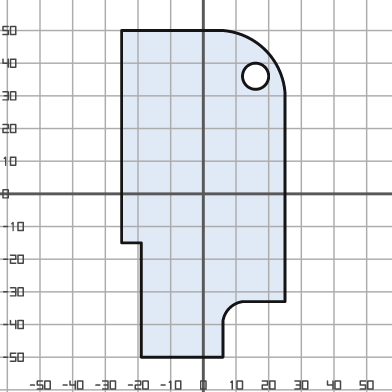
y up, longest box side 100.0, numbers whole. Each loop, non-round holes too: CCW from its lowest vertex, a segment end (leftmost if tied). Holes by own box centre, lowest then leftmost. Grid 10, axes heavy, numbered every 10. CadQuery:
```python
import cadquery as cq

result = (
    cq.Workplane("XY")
    .moveTo(-19.0, -50.0)
    .lineTo(6.0, -50.0)
    .lineTo(6.0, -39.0)
    .threePointArc((8.0, -35.0), (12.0, -33.0))
    .lineTo(25.0, -33.0)
    .lineTo(25.0, 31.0)
    .threePointArc((19.0, 44.0), (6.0, 50.0))
    .lineTo(-25.0, 50.0)
    .lineTo(-25.0, -15.0)
    .lineTo(-19.0, -15.0)
    .close()
    .moveTo(16.0, 36.0)
    .circle(4.0)
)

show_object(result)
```